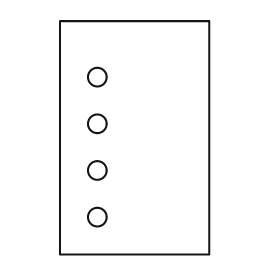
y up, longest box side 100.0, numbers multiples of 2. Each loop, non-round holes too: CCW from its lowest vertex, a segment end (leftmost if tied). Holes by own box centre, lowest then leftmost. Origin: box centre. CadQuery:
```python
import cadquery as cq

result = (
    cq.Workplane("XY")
    .moveTo(-32.0, -50.0)
    .lineTo(32.0, -50.0)
    .lineTo(32.0, 50.0)
    .lineTo(-32.0, 50.0)
    .close()
    .moveTo(-16.0, -34.0)
    .circle(4.0)
    .moveTo(-16.0, -14.0)
    .circle(4.0)
    .moveTo(-16.0, 6.0)
    .circle(4.0)
    .moveTo(-16.0, 26.0)
    .circle(4.0)
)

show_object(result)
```